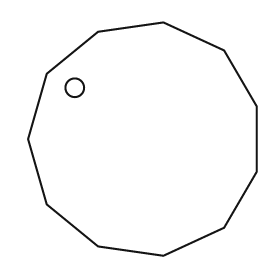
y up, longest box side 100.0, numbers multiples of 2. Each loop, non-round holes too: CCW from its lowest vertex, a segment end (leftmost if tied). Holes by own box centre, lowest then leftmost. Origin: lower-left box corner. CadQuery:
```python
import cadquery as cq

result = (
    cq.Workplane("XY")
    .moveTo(58.0, 0.0)
    .lineTo(84.0, 12.0)
    .lineTo(98.0, 36.0)
    .lineTo(98.0, 64.0)
    .lineTo(84.0, 88.0)
    .lineTo(58.0, 100.0)
    .lineTo(30.0, 96.0)
    .lineTo(8.0, 78.0)
    .lineTo(0.0, 50.0)
    .lineTo(8.0, 22.0)
    .lineTo(30.0, 4.0)
    .close()
    .moveTo(20.0, 72.0)
    .circle(4.0)
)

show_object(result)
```